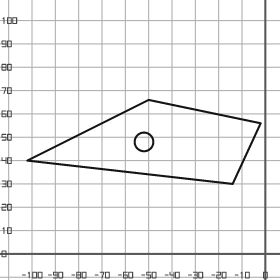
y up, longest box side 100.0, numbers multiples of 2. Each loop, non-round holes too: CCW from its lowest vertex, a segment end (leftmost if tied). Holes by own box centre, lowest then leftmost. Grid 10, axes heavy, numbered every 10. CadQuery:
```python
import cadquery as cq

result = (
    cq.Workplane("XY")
    .moveTo(-14.0, 30.0)
    .lineTo(-2.0, 56.0)
    .lineTo(-50.0, 66.0)
    .lineTo(-102.0, 40.0)
    .close()
    .moveTo(-52.0, 48.0)
    .circle(4.0)
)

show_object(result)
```